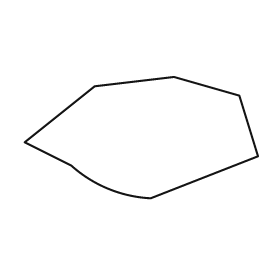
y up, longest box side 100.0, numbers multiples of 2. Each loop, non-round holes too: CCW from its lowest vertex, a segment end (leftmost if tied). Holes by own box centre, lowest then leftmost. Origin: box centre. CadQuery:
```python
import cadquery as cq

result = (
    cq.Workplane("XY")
    .moveTo(4.0, -26.0)
    .lineTo(50.0, -8.0)
    .lineTo(42.0, 18.0)
    .lineTo(14.0, 26.0)
    .lineTo(-20.0, 22.0)
    .lineTo(-50.0, -2.0)
    .lineTo(-30.0, -12.0)
    .threePointArc((-14.0, -22.0), (4.0, -26.0))
    .close()
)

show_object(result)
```